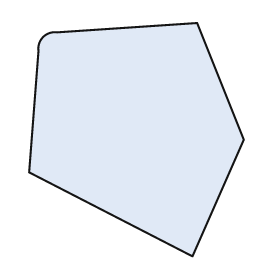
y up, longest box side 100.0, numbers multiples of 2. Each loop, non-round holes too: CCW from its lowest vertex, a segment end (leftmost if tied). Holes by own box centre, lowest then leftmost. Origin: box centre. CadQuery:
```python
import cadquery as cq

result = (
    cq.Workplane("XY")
    .moveTo(24.0, -50.0)
    .lineTo(46.0, 0.0)
    .lineTo(26.0, 50.0)
    .lineTo(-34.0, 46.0)
    .threePointArc((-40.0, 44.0), (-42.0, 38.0))
    .lineTo(-46.0, -14.0)
    .close()
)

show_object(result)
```